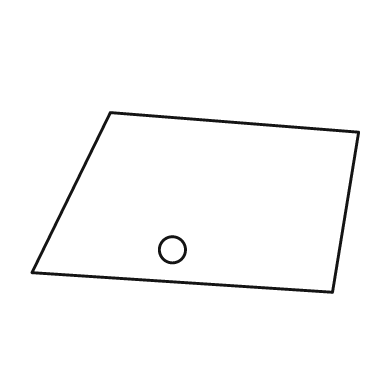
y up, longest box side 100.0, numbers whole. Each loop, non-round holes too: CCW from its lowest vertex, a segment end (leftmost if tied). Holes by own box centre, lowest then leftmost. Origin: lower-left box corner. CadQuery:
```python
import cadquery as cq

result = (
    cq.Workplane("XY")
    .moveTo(92.0, 0.0)
    .lineTo(100.0, 49.0)
    .lineTo(24.0, 55.0)
    .lineTo(0.0, 6.0)
    .close()
    .moveTo(43.0, 13.0)
    .circle(4.0)
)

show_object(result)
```